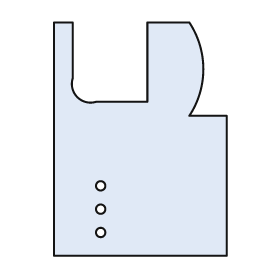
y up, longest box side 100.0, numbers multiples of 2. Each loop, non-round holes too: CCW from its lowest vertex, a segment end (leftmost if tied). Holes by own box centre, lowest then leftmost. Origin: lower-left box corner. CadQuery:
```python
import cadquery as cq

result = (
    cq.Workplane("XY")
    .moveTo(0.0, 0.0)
    .lineTo(74.0, 0.0)
    .lineTo(74.0, 60.0)
    .lineTo(58.0, 60.0)
    .threePointArc((64.0, 80.0), (58.0, 100.0))
    .lineTo(40.0, 100.0)
    .lineTo(40.0, 66.0)
    .lineTo(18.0, 66.0)
    .threePointArc((10.0, 68.0), (8.0, 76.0))
    .lineTo(8.0, 100.0)
    .lineTo(0.0, 100.0)
    .close()
    .moveTo(20.0, 10.0)
    .circle(2.0)
    .moveTo(20.0, 20.0)
    .circle(2.0)
    .moveTo(20.0, 30.0)
    .circle(2.0)
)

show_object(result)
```